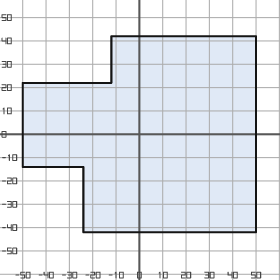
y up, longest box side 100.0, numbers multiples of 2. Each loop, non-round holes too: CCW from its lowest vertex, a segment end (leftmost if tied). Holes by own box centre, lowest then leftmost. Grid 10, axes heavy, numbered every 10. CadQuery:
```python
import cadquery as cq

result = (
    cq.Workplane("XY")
    .moveTo(-24.0, -42.0)
    .lineTo(50.0, -42.0)
    .lineTo(50.0, 42.0)
    .lineTo(-12.0, 42.0)
    .lineTo(-12.0, 22.0)
    .lineTo(-50.0, 22.0)
    .lineTo(-50.0, -14.0)
    .lineTo(-24.0, -14.0)
    .close()
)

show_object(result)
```